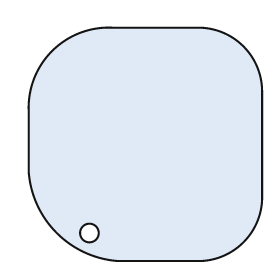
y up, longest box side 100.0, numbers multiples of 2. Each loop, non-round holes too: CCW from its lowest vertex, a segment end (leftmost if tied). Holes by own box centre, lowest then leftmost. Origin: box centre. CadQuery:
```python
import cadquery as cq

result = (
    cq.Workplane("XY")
    .moveTo(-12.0, -50.0)
    .lineTo(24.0, -50.0)
    .threePointArc((42.0, -42.0), (50.0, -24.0))
    .lineTo(50.0, 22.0)
    .threePointArc((42.0, 42.0), (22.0, 50.0))
    .lineTo(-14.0, 50.0)
    .threePointArc((-40.0, 40.0), (-50.0, 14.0))
    .lineTo(-50.0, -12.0)
    .threePointArc((-38.0, -38.0), (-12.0, -50.0))
    .close()
    .moveTo(-24.0, -38.0)
    .circle(4.0)
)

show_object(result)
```